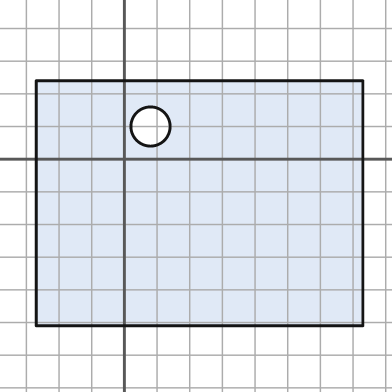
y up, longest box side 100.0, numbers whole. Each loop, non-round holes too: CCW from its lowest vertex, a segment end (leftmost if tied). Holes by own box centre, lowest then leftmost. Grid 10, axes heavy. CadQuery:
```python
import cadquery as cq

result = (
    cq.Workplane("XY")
    .moveTo(-27.0, -51.0)
    .lineTo(73.0, -51.0)
    .lineTo(73.0, 24.0)
    .lineTo(-27.0, 24.0)
    .close()
    .moveTo(8.0, 10.0)
    .circle(6.0)
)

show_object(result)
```